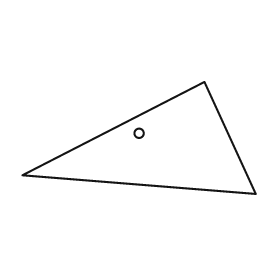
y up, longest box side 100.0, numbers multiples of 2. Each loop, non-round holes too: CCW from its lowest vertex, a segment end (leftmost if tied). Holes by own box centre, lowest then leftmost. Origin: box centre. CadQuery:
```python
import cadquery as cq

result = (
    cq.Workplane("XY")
    .moveTo(50.0, -24.0)
    .lineTo(28.0, 24.0)
    .lineTo(-50.0, -16.0)
    .close()
    .moveTo(0.0, 2.0)
    .circle(2.0)
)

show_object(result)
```